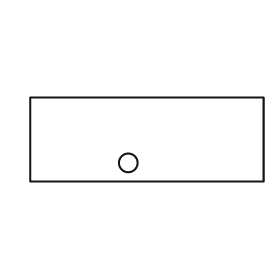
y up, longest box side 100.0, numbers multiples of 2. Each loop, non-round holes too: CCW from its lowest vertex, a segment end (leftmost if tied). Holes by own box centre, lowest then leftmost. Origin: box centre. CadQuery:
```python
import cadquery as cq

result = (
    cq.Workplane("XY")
    .moveTo(-50.0, -18.0)
    .lineTo(50.0, -18.0)
    .lineTo(50.0, 18.0)
    .lineTo(-50.0, 18.0)
    .close()
    .moveTo(-8.0, -10.0)
    .circle(4.0)
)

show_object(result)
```